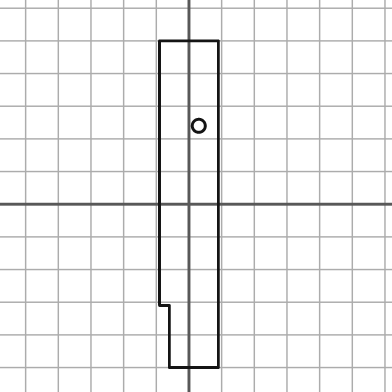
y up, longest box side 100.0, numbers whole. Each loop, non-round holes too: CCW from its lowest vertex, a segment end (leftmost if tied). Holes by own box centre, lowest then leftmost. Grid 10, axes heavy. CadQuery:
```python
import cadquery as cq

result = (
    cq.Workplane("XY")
    .moveTo(-6.0, -50.0)
    .lineTo(9.0, -50.0)
    .lineTo(9.0, 50.0)
    .lineTo(-9.0, 50.0)
    .lineTo(-9.0, -31.0)
    .lineTo(-6.0, -31.0)
    .close()
    .moveTo(3.0, 24.0)
    .circle(2.0)
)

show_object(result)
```